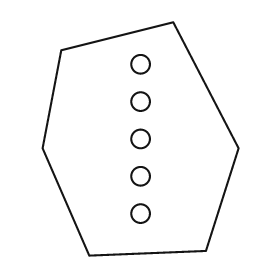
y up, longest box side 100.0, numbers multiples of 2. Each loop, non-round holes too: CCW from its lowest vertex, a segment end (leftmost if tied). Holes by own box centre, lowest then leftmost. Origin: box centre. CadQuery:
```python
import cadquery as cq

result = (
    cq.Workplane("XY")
    .moveTo(-22.0, -50.0)
    .lineTo(28.0, -48.0)
    .lineTo(42.0, -4.0)
    .lineTo(14.0, 50.0)
    .lineTo(-34.0, 38.0)
    .lineTo(-42.0, -4.0)
    .close()
    .moveTo(0.0, -32.0)
    .circle(4.0)
    .moveTo(0.0, -16.0)
    .circle(4.0)
    .moveTo(0.0, 0.0)
    .circle(4.0)
    .moveTo(0.0, 16.0)
    .circle(4.0)
    .moveTo(0.0, 32.0)
    .circle(4.0)
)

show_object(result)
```